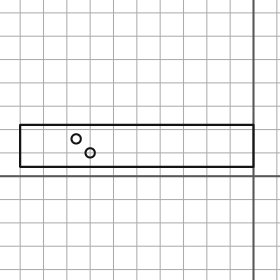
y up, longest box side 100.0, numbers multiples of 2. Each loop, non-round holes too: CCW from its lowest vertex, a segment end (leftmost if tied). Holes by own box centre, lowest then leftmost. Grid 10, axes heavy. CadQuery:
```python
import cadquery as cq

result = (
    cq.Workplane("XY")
    .moveTo(-100.0, 4.0)
    .lineTo(0.0, 4.0)
    .lineTo(0.0, 22.0)
    .lineTo(-100.0, 22.0)
    .close()
    .moveTo(-70.0, 10.0)
    .circle(2.0)
    .moveTo(-76.0, 16.0)
    .circle(2.0)
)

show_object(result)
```